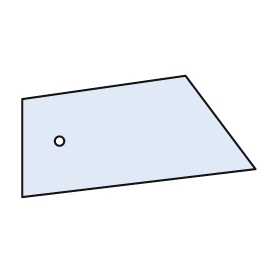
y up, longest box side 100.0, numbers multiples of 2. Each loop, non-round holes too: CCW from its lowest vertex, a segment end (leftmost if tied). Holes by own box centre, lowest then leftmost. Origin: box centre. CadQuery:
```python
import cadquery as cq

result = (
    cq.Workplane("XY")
    .moveTo(-50.0, -26.0)
    .lineTo(50.0, -14.0)
    .lineTo(20.0, 26.0)
    .lineTo(-50.0, 16.0)
    .close()
    .moveTo(-34.0, -2.0)
    .circle(2.0)
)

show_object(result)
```